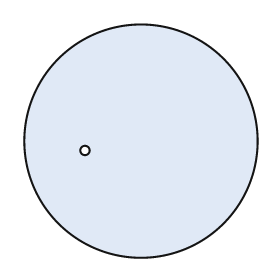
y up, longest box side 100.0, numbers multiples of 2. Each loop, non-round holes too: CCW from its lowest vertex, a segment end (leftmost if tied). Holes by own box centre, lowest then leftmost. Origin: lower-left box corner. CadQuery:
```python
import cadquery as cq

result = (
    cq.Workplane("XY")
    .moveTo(50.0, 50.0)
    .circle(50.0)
    .moveTo(26.0, 46.0)
    .circle(2.0)
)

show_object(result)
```